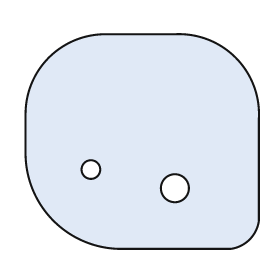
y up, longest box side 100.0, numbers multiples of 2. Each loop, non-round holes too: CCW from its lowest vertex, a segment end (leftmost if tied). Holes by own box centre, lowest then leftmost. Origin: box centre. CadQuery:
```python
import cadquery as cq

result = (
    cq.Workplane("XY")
    .moveTo(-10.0, -46.0)
    .lineTo(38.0, -46.0)
    .threePointArc((46.0, -42.0), (50.0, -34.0))
    .lineTo(50.0, 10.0)
    .threePointArc((40.0, 36.0), (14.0, 46.0))
    .lineTo(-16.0, 46.0)
    .threePointArc((-40.0, 36.0), (-50.0, 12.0))
    .lineTo(-50.0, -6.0)
    .threePointArc((-38.0, -34.0), (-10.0, -46.0))
    .close()
    .moveTo(14.0, -20.0)
    .circle(6.0)
    .moveTo(-22.0, -12.0)
    .circle(4.0)
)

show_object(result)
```